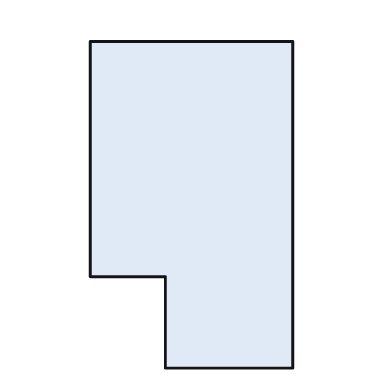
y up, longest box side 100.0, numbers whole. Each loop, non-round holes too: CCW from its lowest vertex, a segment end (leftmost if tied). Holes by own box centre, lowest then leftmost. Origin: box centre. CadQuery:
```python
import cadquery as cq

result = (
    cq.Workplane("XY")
    .moveTo(-8.0, -50.0)
    .lineTo(31.0, -50.0)
    .lineTo(31.0, 50.0)
    .lineTo(-31.0, 50.0)
    .lineTo(-31.0, -22.0)
    .lineTo(-8.0, -22.0)
    .close()
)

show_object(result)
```